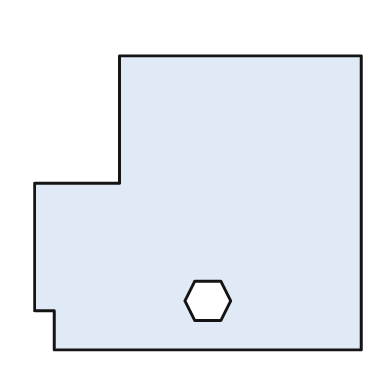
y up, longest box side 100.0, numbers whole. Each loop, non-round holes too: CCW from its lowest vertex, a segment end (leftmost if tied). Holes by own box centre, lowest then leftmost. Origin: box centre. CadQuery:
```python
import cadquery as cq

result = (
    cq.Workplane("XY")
    .moveTo(-44.0, -45.0)
    .lineTo(50.0, -45.0)
    .lineTo(50.0, 45.0)
    .lineTo(-24.0, 45.0)
    .lineTo(-24.0, 6.0)
    .lineTo(-50.0, 6.0)
    .lineTo(-50.0, -33.0)
    .lineTo(-44.0, -33.0)
    .close()
    .moveTo(-1.0, -36.0)
    .lineTo(7.0, -36.0)
    .lineTo(10.0, -30.0)
    .lineTo(7.0, -24.0)
    .lineTo(-1.0, -24.0)
    .lineTo(-4.0, -30.0)
    .close()
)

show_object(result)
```